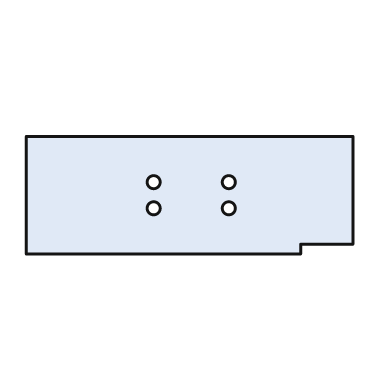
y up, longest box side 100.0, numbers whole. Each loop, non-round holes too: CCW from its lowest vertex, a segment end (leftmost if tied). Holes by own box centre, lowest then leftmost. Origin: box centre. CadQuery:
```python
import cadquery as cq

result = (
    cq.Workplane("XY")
    .moveTo(-50.0, -18.0)
    .lineTo(34.0, -18.0)
    .lineTo(34.0, -15.0)
    .lineTo(50.0, -15.0)
    .lineTo(50.0, 18.0)
    .lineTo(-50.0, 18.0)
    .close()
    .moveTo(-11.0, -4.0)
    .circle(2.0)
    .moveTo(12.0, -4.0)
    .circle(2.0)
    .moveTo(-11.0, 4.0)
    .circle(2.0)
    .moveTo(12.0, 4.0)
    .circle(2.0)
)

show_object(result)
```